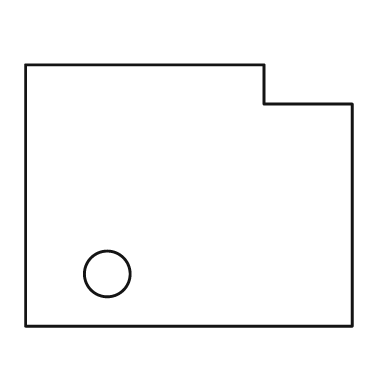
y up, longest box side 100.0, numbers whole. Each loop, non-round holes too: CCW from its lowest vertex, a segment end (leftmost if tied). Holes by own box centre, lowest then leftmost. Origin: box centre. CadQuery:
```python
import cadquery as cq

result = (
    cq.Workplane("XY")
    .moveTo(-50.0, -40.0)
    .lineTo(50.0, -40.0)
    .lineTo(50.0, 28.0)
    .lineTo(23.0, 28.0)
    .lineTo(23.0, 40.0)
    .lineTo(-50.0, 40.0)
    .close()
    .moveTo(-25.0, -24.0)
    .circle(7.0)
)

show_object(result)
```